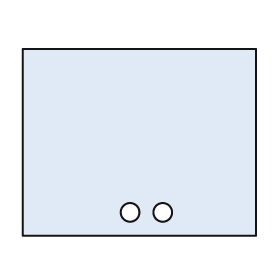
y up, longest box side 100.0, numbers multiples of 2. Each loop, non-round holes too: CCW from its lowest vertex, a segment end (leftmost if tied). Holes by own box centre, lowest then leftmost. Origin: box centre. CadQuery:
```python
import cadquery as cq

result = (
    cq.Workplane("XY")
    .moveTo(-50.0, -40.0)
    .lineTo(50.0, -40.0)
    .lineTo(50.0, 40.0)
    .lineTo(-50.0, 40.0)
    .close()
    .moveTo(-4.0, -30.0)
    .circle(4.0)
    .moveTo(10.0, -30.0)
    .circle(4.0)
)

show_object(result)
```